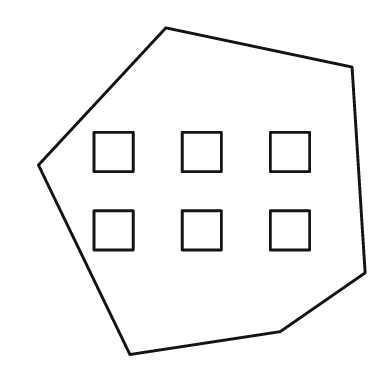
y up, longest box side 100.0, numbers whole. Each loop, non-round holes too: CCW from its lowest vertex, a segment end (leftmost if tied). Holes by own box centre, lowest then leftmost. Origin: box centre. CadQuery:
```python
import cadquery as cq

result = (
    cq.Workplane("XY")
    .moveTo(-22.0, -50.0)
    .lineTo(24.0, -43.0)
    .lineTo(50.0, -25.0)
    .lineTo(46.0, 38.0)
    .lineTo(-11.0, 50.0)
    .lineTo(-50.0, 8.0)
    .close()
    .moveTo(-33.0, -18.0)
    .lineTo(-21.0, -18.0)
    .lineTo(-21.0, -6.0)
    .lineTo(-33.0, -6.0)
    .close()
    .moveTo(-6.0, -18.0)
    .lineTo(6.0, -18.0)
    .lineTo(6.0, -6.0)
    .lineTo(-6.0, -6.0)
    .close()
    .moveTo(21.0, -18.0)
    .lineTo(33.0, -18.0)
    .lineTo(33.0, -6.0)
    .lineTo(21.0, -6.0)
    .close()
    .moveTo(-33.0, 6.0)
    .lineTo(-21.0, 6.0)
    .lineTo(-21.0, 18.0)
    .lineTo(-33.0, 18.0)
    .close()
    .moveTo(-6.0, 6.0)
    .lineTo(6.0, 6.0)
    .lineTo(6.0, 18.0)
    .lineTo(-6.0, 18.0)
    .close()
    .moveTo(21.0, 6.0)
    .lineTo(33.0, 6.0)
    .lineTo(33.0, 18.0)
    .lineTo(21.0, 18.0)
    .close()
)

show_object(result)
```